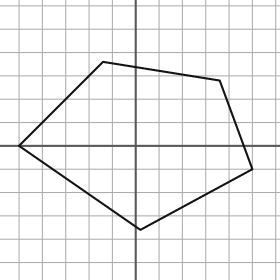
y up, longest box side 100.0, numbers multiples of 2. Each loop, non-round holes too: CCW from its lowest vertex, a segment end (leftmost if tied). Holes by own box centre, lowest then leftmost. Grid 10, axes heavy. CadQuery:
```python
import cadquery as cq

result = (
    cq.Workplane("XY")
    .moveTo(2.0, -36.0)
    .lineTo(50.0, -10.0)
    .lineTo(36.0, 28.0)
    .lineTo(-14.0, 36.0)
    .lineTo(-50.0, 0.0)
    .close()
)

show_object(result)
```